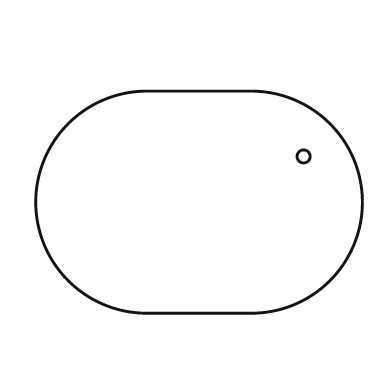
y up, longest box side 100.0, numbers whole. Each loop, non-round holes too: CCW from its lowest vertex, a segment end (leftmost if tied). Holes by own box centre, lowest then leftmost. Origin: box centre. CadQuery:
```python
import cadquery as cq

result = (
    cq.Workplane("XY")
    .moveTo(-16.0, -34.0)
    .lineTo(16.0, -34.0)
    .threePointArc((50.0, 0.0), (16.0, 34.0))
    .lineTo(-16.0, 34.0)
    .threePointArc((-50.0, 0.0), (-16.0, -34.0))
    .close()
    .moveTo(32.0, 14.0)
    .circle(2.0)
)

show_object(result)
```